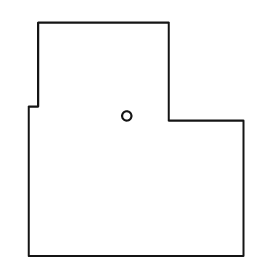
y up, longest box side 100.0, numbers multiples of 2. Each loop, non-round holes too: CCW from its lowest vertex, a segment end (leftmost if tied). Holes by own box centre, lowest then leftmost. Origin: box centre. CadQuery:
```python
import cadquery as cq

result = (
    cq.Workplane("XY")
    .moveTo(-46.0, -50.0)
    .lineTo(46.0, -50.0)
    .lineTo(46.0, 8.0)
    .lineTo(14.0, 8.0)
    .lineTo(14.0, 50.0)
    .lineTo(-42.0, 50.0)
    .lineTo(-42.0, 14.0)
    .lineTo(-46.0, 14.0)
    .close()
    .moveTo(-4.0, 10.0)
    .circle(2.0)
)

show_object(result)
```